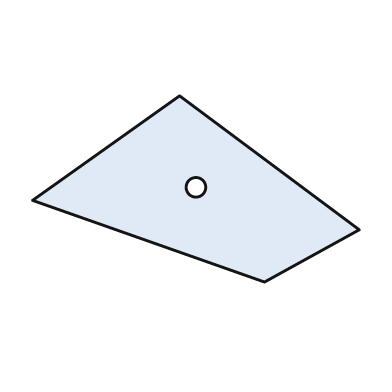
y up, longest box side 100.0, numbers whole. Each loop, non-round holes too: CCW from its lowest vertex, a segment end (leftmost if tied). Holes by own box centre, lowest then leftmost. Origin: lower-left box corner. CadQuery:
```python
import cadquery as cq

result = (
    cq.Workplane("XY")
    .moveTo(71.0, 0.0)
    .lineTo(100.0, 16.0)
    .lineTo(45.0, 57.0)
    .lineTo(0.0, 25.0)
    .close()
    .moveTo(50.0, 29.0)
    .circle(3.0)
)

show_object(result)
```